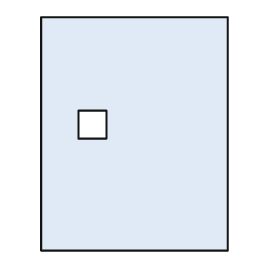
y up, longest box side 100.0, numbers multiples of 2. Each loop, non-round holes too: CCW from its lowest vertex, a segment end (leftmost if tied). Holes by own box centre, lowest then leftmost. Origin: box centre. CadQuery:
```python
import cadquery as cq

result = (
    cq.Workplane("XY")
    .moveTo(-40.0, -50.0)
    .lineTo(40.0, -50.0)
    .lineTo(40.0, 50.0)
    .lineTo(-40.0, 50.0)
    .close()
    .moveTo(-24.0, -2.0)
    .lineTo(-12.0, -2.0)
    .lineTo(-12.0, 10.0)
    .lineTo(-24.0, 10.0)
    .close()
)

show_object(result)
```